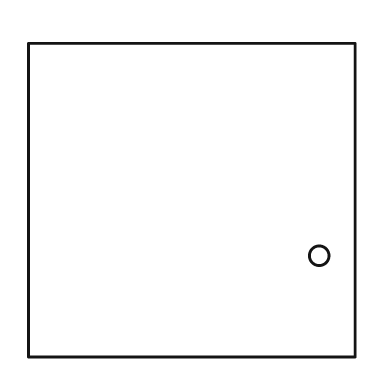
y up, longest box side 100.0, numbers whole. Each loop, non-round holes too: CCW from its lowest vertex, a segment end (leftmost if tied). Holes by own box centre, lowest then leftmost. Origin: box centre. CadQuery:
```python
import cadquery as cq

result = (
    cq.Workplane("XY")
    .moveTo(-50.0, -48.0)
    .lineTo(50.0, -48.0)
    .lineTo(50.0, 48.0)
    .lineTo(-50.0, 48.0)
    .close()
    .moveTo(39.0, -17.0)
    .circle(3.0)
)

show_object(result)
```